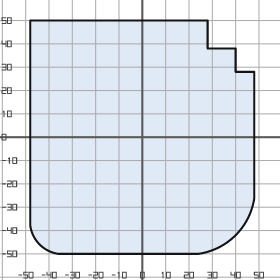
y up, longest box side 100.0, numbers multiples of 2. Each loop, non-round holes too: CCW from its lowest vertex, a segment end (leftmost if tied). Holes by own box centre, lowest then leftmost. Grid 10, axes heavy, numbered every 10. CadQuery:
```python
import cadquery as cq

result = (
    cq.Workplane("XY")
    .moveTo(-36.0, -50.0)
    .lineTo(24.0, -50.0)
    .threePointArc((40.0, -42.0), (48.0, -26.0))
    .lineTo(48.0, 28.0)
    .lineTo(40.0, 28.0)
    .lineTo(40.0, 38.0)
    .lineTo(28.0, 38.0)
    .lineTo(28.0, 50.0)
    .lineTo(-48.0, 50.0)
    .lineTo(-48.0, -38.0)
    .threePointArc((-44.0, -46.0), (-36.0, -50.0))
    .close()
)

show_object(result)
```